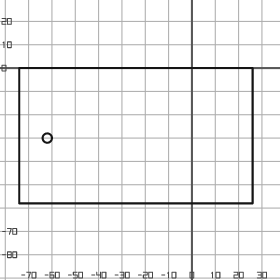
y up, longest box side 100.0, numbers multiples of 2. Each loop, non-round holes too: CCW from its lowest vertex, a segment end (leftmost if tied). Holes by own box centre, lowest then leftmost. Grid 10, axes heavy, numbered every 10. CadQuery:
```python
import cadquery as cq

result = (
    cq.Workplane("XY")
    .moveTo(-74.0, -58.0)
    .lineTo(26.0, -58.0)
    .lineTo(26.0, 0.0)
    .lineTo(-74.0, 0.0)
    .close()
    .moveTo(-62.0, -30.0)
    .circle(2.0)
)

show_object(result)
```